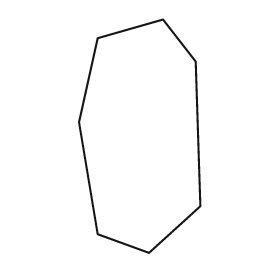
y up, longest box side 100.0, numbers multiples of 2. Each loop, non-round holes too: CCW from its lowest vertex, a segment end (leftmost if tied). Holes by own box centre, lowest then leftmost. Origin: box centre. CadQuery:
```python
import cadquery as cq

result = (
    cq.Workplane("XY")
    .moveTo(4.0, -50.0)
    .lineTo(26.0, -30.0)
    .lineTo(24.0, 32.0)
    .lineTo(10.0, 50.0)
    .lineTo(-18.0, 42.0)
    .lineTo(-26.0, 6.0)
    .lineTo(-18.0, -42.0)
    .close()
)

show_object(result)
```